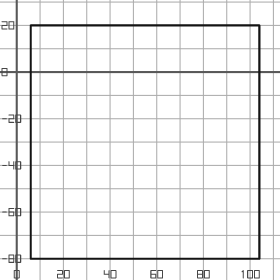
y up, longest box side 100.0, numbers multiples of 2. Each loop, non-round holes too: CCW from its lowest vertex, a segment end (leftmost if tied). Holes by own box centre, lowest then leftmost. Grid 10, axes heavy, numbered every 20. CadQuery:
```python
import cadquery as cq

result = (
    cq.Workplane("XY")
    .moveTo(6.0, -80.0)
    .lineTo(104.0, -80.0)
    .lineTo(104.0, 20.0)
    .lineTo(6.0, 20.0)
    .close()
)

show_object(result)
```